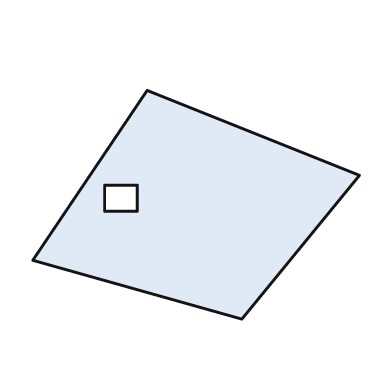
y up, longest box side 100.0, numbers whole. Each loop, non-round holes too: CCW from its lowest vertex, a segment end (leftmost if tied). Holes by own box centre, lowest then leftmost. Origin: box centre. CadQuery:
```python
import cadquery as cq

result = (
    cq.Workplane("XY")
    .moveTo(14.0, -35.0)
    .lineTo(50.0, 9.0)
    .lineTo(-15.0, 35.0)
    .lineTo(-50.0, -17.0)
    .close()
    .moveTo(-28.0, -2.0)
    .lineTo(-18.0, -2.0)
    .lineTo(-18.0, 6.0)
    .lineTo(-28.0, 6.0)
    .close()
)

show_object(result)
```